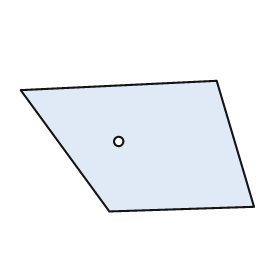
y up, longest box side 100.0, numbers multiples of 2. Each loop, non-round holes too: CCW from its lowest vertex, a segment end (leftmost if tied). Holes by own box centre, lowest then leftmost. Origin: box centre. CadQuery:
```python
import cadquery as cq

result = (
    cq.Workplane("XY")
    .moveTo(-12.0, -28.0)
    .lineTo(50.0, -26.0)
    .lineTo(34.0, 28.0)
    .lineTo(-50.0, 24.0)
    .close()
    .moveTo(-8.0, 2.0)
    .circle(2.0)
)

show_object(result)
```